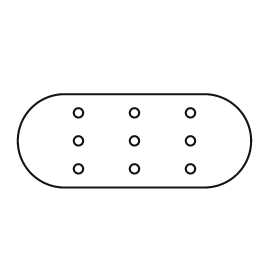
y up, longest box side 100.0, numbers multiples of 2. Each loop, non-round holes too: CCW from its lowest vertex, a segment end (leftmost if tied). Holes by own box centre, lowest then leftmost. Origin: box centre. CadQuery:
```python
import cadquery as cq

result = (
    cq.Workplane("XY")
    .moveTo(-30.0, -20.0)
    .lineTo(30.0, -20.0)
    .threePointArc((50.0, 0.0), (30.0, 20.0))
    .lineTo(-30.0, 20.0)
    .threePointArc((-50.0, 0.0), (-30.0, -20.0))
    .close()
    .moveTo(-24.0, -12.0)
    .circle(2.0)
    .moveTo(0.0, -12.0)
    .circle(2.0)
    .moveTo(24.0, -12.0)
    .circle(2.0)
    .moveTo(-24.0, 0.0)
    .circle(2.0)
    .moveTo(0.0, 0.0)
    .circle(2.0)
    .moveTo(24.0, 0.0)
    .circle(2.0)
    .moveTo(-24.0, 12.0)
    .circle(2.0)
    .moveTo(0.0, 12.0)
    .circle(2.0)
    .moveTo(24.0, 12.0)
    .circle(2.0)
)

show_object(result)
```